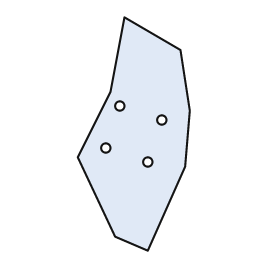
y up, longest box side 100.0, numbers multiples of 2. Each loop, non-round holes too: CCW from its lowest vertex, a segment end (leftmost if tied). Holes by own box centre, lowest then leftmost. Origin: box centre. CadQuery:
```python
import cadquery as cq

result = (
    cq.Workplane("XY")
    .moveTo(6.0, -50.0)
    .lineTo(22.0, -14.0)
    .lineTo(24.0, 10.0)
    .lineTo(20.0, 36.0)
    .lineTo(-4.0, 50.0)
    .lineTo(-10.0, 18.0)
    .lineTo(-24.0, -10.0)
    .lineTo(-8.0, -44.0)
    .close()
    .moveTo(6.0, -12.0)
    .circle(2.0)
    .moveTo(-12.0, -6.0)
    .circle(2.0)
    .moveTo(12.0, 6.0)
    .circle(2.0)
    .moveTo(-6.0, 12.0)
    .circle(2.0)
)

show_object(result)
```